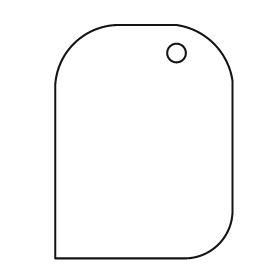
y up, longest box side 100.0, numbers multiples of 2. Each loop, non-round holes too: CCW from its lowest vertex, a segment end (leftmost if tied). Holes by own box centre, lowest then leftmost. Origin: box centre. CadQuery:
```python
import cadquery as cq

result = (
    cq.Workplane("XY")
    .moveTo(-38.0, -50.0)
    .lineTo(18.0, -50.0)
    .threePointArc((32.0, -44.0), (38.0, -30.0))
    .lineTo(38.0, 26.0)
    .threePointArc((30.0, 42.0), (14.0, 50.0))
    .lineTo(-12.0, 50.0)
    .threePointArc((-30.0, 42.0), (-38.0, 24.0))
    .close()
    .moveTo(14.0, 38.0)
    .circle(4.0)
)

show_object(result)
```